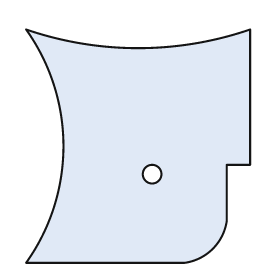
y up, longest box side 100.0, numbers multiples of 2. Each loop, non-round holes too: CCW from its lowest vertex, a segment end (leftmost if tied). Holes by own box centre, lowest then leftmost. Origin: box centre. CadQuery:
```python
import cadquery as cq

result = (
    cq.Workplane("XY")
    .moveTo(-48.0, -50.0)
    .lineTo(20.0, -50.0)
    .threePointArc((32.0, -44.0), (38.0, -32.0))
    .lineTo(38.0, -8.0)
    .lineTo(48.0, -8.0)
    .lineTo(48.0, 50.0)
    .threePointArc((0.0, 42.0), (-48.0, 50.0))
    .threePointArc((-32.0, 0.0), (-48.0, -50.0))
    .close()
    .moveTo(6.0, -12.0)
    .circle(4.0)
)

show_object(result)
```